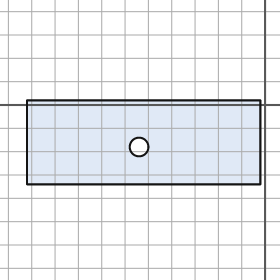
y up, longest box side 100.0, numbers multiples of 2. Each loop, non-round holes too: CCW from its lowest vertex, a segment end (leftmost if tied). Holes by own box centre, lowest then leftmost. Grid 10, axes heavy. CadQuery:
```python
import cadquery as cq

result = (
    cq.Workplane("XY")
    .moveTo(-102.0, -34.0)
    .lineTo(-2.0, -34.0)
    .lineTo(-2.0, 2.0)
    .lineTo(-102.0, 2.0)
    .close()
    .moveTo(-54.0, -18.0)
    .circle(4.0)
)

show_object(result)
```